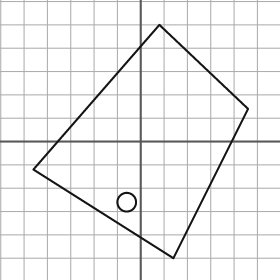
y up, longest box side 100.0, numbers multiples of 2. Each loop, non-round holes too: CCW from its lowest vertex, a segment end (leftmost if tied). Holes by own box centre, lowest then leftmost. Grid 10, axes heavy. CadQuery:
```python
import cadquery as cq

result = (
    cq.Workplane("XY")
    .moveTo(14.0, -50.0)
    .lineTo(46.0, 14.0)
    .lineTo(8.0, 50.0)
    .lineTo(-46.0, -12.0)
    .close()
    .moveTo(-6.0, -26.0)
    .circle(4.0)
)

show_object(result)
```